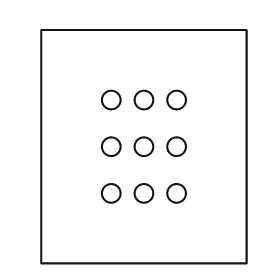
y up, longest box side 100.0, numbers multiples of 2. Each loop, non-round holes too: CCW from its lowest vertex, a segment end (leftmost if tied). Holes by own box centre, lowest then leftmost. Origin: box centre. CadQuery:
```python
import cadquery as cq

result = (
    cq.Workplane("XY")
    .moveTo(-44.0, -50.0)
    .lineTo(44.0, -50.0)
    .lineTo(44.0, 50.0)
    .lineTo(-44.0, 50.0)
    .close()
    .moveTo(-14.0, -20.0)
    .circle(4.0)
    .moveTo(0.0, -20.0)
    .circle(4.0)
    .moveTo(14.0, -20.0)
    .circle(4.0)
    .moveTo(-14.0, 0.0)
    .circle(4.0)
    .moveTo(0.0, 0.0)
    .circle(4.0)
    .moveTo(14.0, 0.0)
    .circle(4.0)
    .moveTo(-14.0, 20.0)
    .circle(4.0)
    .moveTo(0.0, 20.0)
    .circle(4.0)
    .moveTo(14.0, 20.0)
    .circle(4.0)
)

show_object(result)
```